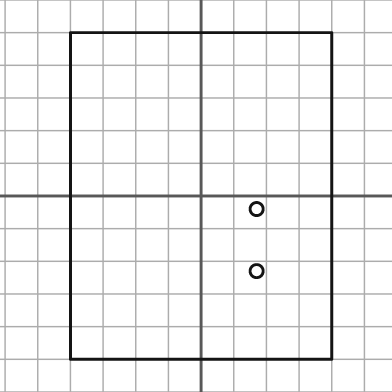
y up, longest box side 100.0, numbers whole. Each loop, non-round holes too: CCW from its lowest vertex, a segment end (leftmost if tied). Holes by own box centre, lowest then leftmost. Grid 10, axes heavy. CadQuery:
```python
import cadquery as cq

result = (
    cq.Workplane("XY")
    .moveTo(-40.0, -50.0)
    .lineTo(40.0, -50.0)
    .lineTo(40.0, 50.0)
    .lineTo(-40.0, 50.0)
    .close()
    .moveTo(17.0, -23.0)
    .circle(2.0)
    .moveTo(17.0, -4.0)
    .circle(2.0)
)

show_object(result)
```